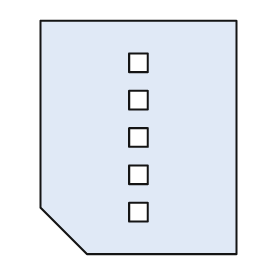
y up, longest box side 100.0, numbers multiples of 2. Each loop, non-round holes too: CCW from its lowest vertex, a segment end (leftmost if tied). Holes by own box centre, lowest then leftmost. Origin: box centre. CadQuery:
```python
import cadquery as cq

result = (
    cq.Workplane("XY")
    .moveTo(-22.0, -50.0)
    .lineTo(42.0, -50.0)
    .lineTo(42.0, 50.0)
    .lineTo(-42.0, 50.0)
    .lineTo(-42.0, -30.0)
    .close()
    .moveTo(-4.0, -36.0)
    .lineTo(4.0, -36.0)
    .lineTo(4.0, -28.0)
    .lineTo(-4.0, -28.0)
    .close()
    .moveTo(-4.0, -20.0)
    .lineTo(4.0, -20.0)
    .lineTo(4.0, -12.0)
    .lineTo(-4.0, -12.0)
    .close()
    .moveTo(-4.0, -4.0)
    .lineTo(4.0, -4.0)
    .lineTo(4.0, 4.0)
    .lineTo(-4.0, 4.0)
    .close()
    .moveTo(-4.0, 12.0)
    .lineTo(4.0, 12.0)
    .lineTo(4.0, 20.0)
    .lineTo(-4.0, 20.0)
    .close()
    .moveTo(-4.0, 28.0)
    .lineTo(4.0, 28.0)
    .lineTo(4.0, 36.0)
    .lineTo(-4.0, 36.0)
    .close()
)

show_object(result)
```